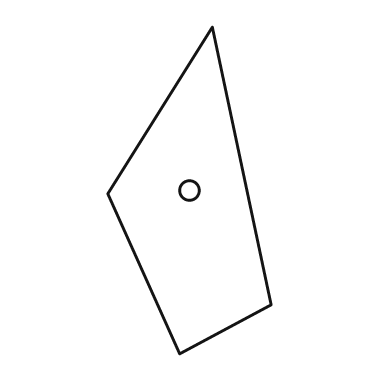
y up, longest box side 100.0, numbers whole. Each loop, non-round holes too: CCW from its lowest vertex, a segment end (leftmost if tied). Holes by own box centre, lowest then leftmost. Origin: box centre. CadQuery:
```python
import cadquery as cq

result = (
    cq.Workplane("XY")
    .moveTo(-3.0, -50.0)
    .lineTo(25.0, -35.0)
    .lineTo(7.0, 50.0)
    .lineTo(-25.0, -1.0)
    .close()
    .moveTo(0.0, 0.0)
    .circle(3.0)
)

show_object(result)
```